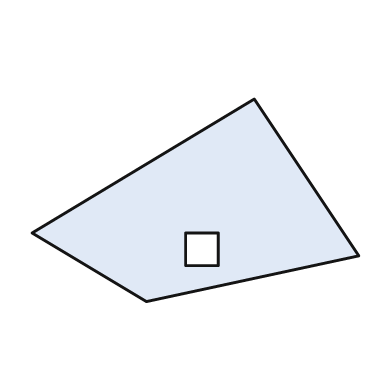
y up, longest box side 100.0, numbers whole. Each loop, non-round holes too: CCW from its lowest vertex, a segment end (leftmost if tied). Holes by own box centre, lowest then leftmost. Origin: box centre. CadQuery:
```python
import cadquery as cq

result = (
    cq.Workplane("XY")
    .moveTo(-15.0, -31.0)
    .lineTo(50.0, -17.0)
    .lineTo(18.0, 31.0)
    .lineTo(-50.0, -10.0)
    .close()
    .moveTo(-3.0, -20.0)
    .lineTo(7.0, -20.0)
    .lineTo(7.0, -10.0)
    .lineTo(-3.0, -10.0)
    .close()
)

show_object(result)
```